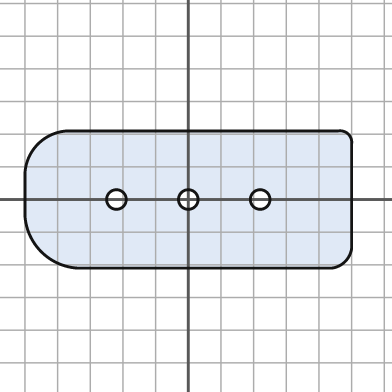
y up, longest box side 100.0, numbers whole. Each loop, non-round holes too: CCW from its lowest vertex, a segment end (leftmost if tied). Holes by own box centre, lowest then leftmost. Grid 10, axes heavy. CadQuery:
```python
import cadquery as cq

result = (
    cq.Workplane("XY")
    .moveTo(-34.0, -21.0)
    .lineTo(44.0, -21.0)
    .threePointArc((48.0, -19.0), (50.0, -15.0))
    .lineTo(50.0, 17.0)
    .threePointArc((49.0, 20.0), (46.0, 21.0))
    .lineTo(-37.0, 21.0)
    .threePointArc((-46.0, 17.0), (-50.0, 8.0))
    .lineTo(-50.0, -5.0)
    .threePointArc((-45.0, -16.0), (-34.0, -21.0))
    .close()
    .moveTo(-22.0, 0.0)
    .circle(3.0)
    .moveTo(0.0, 0.0)
    .circle(3.0)
    .moveTo(22.0, 0.0)
    .circle(3.0)
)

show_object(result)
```